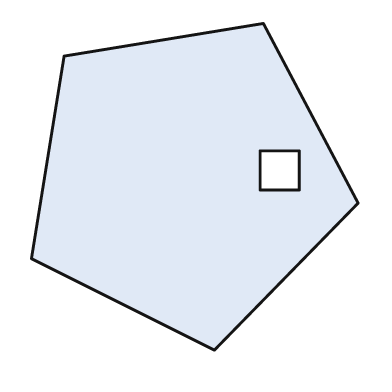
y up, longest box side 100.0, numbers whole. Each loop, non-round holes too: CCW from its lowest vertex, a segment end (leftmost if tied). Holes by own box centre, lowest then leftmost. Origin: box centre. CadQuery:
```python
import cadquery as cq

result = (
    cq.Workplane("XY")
    .moveTo(6.0, -50.0)
    .lineTo(50.0, -5.0)
    .lineTo(21.0, 50.0)
    .lineTo(-40.0, 40.0)
    .lineTo(-50.0, -22.0)
    .close()
    .moveTo(20.0, -1.0)
    .lineTo(32.0, -1.0)
    .lineTo(32.0, 11.0)
    .lineTo(20.0, 11.0)
    .close()
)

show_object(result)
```